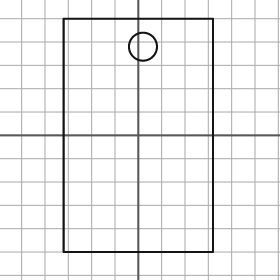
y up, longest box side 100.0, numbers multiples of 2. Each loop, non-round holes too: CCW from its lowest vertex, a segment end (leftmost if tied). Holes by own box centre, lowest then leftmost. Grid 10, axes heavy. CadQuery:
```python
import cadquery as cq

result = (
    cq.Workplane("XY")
    .moveTo(-32.0, -50.0)
    .lineTo(32.0, -50.0)
    .lineTo(32.0, 50.0)
    .lineTo(-32.0, 50.0)
    .close()
    .moveTo(2.0, 38.0)
    .circle(6.0)
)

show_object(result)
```